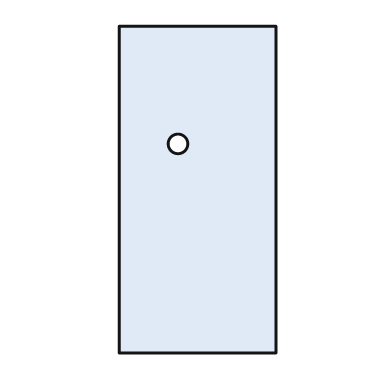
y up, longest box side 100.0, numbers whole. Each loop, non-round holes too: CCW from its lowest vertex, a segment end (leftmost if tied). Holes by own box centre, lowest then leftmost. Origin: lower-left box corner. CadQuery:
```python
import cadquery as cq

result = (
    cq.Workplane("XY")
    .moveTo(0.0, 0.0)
    .lineTo(48.0, 0.0)
    .lineTo(48.0, 100.0)
    .lineTo(0.0, 100.0)
    .close()
    .moveTo(18.0, 64.0)
    .circle(3.0)
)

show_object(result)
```